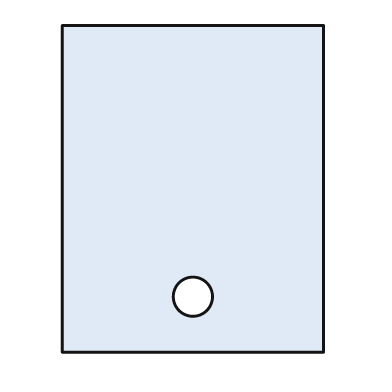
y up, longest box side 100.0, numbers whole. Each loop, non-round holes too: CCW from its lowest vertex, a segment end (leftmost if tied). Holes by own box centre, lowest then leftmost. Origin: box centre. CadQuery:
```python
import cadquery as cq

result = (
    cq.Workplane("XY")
    .moveTo(-40.0, -50.0)
    .lineTo(40.0, -50.0)
    .lineTo(40.0, 50.0)
    .lineTo(-40.0, 50.0)
    .close()
    .moveTo(0.0, -33.0)
    .circle(6.0)
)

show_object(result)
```